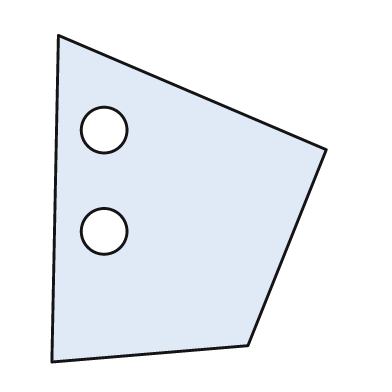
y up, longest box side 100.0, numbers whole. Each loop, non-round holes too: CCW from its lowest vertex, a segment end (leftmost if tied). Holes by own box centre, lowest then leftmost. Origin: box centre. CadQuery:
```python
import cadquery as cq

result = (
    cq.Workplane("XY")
    .moveTo(-42.0, -50.0)
    .lineTo(18.0, -45.0)
    .lineTo(42.0, 15.0)
    .lineTo(-40.0, 50.0)
    .close()
    .moveTo(-26.0, -10.0)
    .circle(7.0)
    .moveTo(-26.0, 21.0)
    .circle(7.0)
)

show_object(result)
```